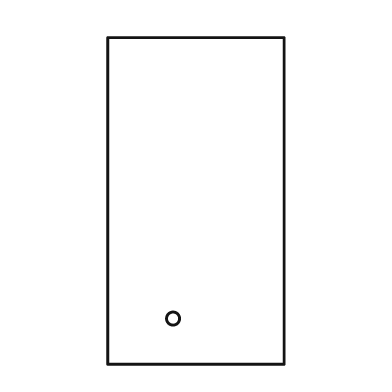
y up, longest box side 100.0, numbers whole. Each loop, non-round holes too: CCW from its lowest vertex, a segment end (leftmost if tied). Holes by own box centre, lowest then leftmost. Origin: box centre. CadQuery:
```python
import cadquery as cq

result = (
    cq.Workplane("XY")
    .moveTo(-27.0, -50.0)
    .lineTo(27.0, -50.0)
    .lineTo(27.0, 50.0)
    .lineTo(-27.0, 50.0)
    .close()
    .moveTo(-7.0, -36.0)
    .circle(2.0)
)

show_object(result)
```